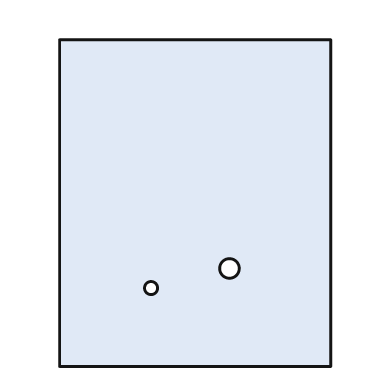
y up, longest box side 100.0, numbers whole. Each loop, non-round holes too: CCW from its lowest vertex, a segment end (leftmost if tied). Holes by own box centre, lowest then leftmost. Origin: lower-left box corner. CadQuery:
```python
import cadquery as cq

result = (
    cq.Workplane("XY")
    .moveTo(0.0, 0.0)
    .lineTo(83.0, 0.0)
    .lineTo(83.0, 100.0)
    .lineTo(0.0, 100.0)
    .close()
    .moveTo(28.0, 24.0)
    .circle(2.0)
    .moveTo(52.0, 30.0)
    .circle(3.0)
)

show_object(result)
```